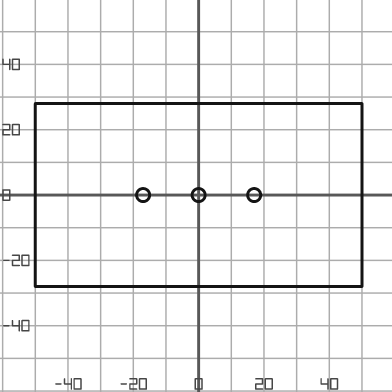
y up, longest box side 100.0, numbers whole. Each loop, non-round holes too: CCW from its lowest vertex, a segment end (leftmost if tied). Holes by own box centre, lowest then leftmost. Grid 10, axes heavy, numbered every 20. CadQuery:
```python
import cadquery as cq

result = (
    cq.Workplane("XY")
    .moveTo(-50.0, -28.0)
    .lineTo(50.0, -28.0)
    .lineTo(50.0, 28.0)
    .lineTo(-50.0, 28.0)
    .close()
    .moveTo(-17.0, 0.0)
    .circle(2.0)
    .moveTo(0.0, 0.0)
    .circle(2.0)
    .moveTo(17.0, 0.0)
    .circle(2.0)
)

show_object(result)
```